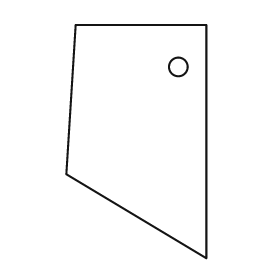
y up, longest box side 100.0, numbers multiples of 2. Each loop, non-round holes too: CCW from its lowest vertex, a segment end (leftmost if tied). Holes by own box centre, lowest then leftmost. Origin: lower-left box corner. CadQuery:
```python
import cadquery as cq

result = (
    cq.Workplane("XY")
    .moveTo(60.0, 0.0)
    .lineTo(60.0, 100.0)
    .lineTo(4.0, 100.0)
    .lineTo(0.0, 36.0)
    .close()
    .moveTo(48.0, 82.0)
    .circle(4.0)
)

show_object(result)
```